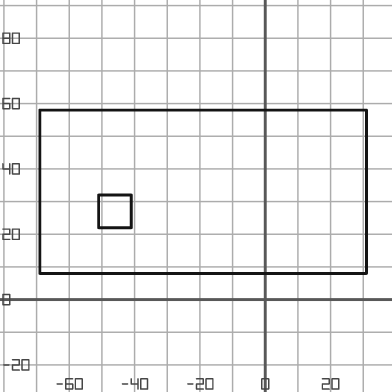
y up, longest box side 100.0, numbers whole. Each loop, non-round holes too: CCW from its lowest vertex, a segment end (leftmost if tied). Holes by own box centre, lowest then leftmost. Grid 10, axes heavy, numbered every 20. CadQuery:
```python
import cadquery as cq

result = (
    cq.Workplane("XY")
    .moveTo(-69.0, 8.0)
    .lineTo(31.0, 8.0)
    .lineTo(31.0, 58.0)
    .lineTo(-69.0, 58.0)
    .close()
    .moveTo(-51.0, 22.0)
    .lineTo(-41.0, 22.0)
    .lineTo(-41.0, 32.0)
    .lineTo(-51.0, 32.0)
    .close()
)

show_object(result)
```